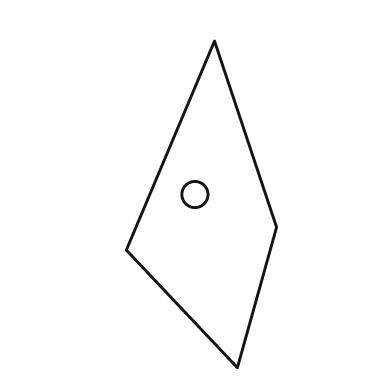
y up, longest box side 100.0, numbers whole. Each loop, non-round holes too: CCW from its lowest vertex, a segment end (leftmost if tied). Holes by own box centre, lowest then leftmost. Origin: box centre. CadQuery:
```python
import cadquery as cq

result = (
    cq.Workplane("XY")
    .moveTo(11.0, -50.0)
    .lineTo(23.0, -7.0)
    .lineTo(4.0, 50.0)
    .lineTo(-23.0, -14.0)
    .close()
    .moveTo(-2.0, 3.0)
    .circle(4.0)
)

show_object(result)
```